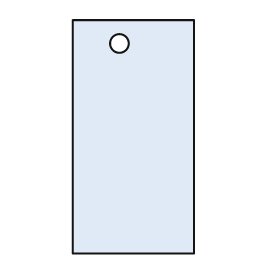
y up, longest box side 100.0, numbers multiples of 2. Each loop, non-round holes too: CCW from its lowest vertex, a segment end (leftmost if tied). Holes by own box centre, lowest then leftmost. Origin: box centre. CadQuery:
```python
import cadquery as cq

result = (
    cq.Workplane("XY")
    .moveTo(-26.0, -50.0)
    .lineTo(26.0, -50.0)
    .lineTo(26.0, 50.0)
    .lineTo(-26.0, 50.0)
    .close()
    .moveTo(-6.0, 40.0)
    .circle(4.0)
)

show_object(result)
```